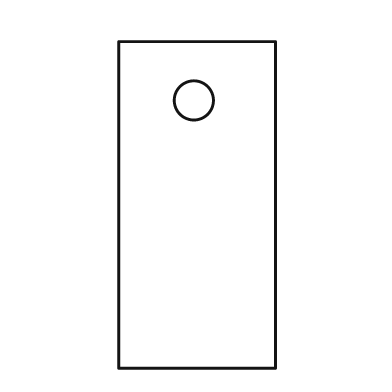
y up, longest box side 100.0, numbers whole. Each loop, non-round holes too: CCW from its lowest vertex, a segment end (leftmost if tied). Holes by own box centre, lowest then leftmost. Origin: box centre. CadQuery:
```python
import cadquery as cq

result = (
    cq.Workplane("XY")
    .moveTo(-24.0, -50.0)
    .lineTo(24.0, -50.0)
    .lineTo(24.0, 50.0)
    .lineTo(-24.0, 50.0)
    .close()
    .moveTo(-1.0, 32.0)
    .circle(6.0)
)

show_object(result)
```